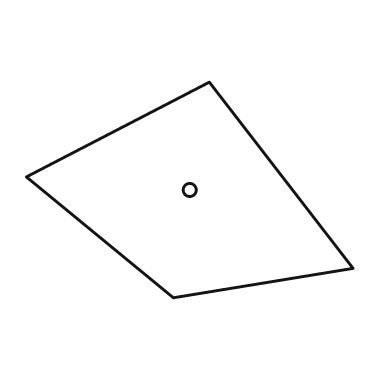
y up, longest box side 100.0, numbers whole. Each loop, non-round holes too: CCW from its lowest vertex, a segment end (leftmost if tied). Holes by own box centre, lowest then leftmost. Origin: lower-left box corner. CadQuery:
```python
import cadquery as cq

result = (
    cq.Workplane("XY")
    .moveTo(45.0, 0.0)
    .lineTo(100.0, 9.0)
    .lineTo(56.0, 66.0)
    .lineTo(0.0, 37.0)
    .close()
    .moveTo(50.0, 33.0)
    .circle(2.0)
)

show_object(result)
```